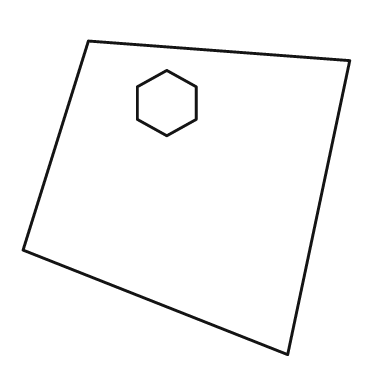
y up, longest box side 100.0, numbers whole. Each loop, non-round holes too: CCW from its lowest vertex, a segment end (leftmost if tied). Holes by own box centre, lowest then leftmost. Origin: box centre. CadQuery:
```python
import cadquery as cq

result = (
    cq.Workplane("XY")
    .moveTo(31.0, -48.0)
    .lineTo(50.0, 42.0)
    .lineTo(-30.0, 48.0)
    .lineTo(-50.0, -16.0)
    .close()
    .moveTo(-6.0, 19.0)
    .lineTo(3.0, 24.0)
    .lineTo(3.0, 34.0)
    .lineTo(-6.0, 39.0)
    .lineTo(-15.0, 34.0)
    .lineTo(-15.0, 24.0)
    .close()
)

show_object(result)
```